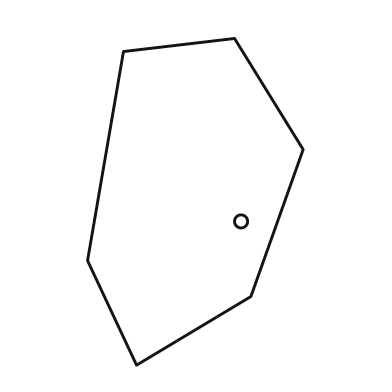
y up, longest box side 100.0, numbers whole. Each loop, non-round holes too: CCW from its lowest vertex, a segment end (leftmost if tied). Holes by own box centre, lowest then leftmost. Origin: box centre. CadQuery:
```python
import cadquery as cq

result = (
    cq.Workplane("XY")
    .moveTo(-18.0, -50.0)
    .lineTo(17.0, -29.0)
    .lineTo(33.0, 16.0)
    .lineTo(12.0, 50.0)
    .lineTo(-22.0, 46.0)
    .lineTo(-33.0, -18.0)
    .close()
    .moveTo(14.0, -6.0)
    .circle(2.0)
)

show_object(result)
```